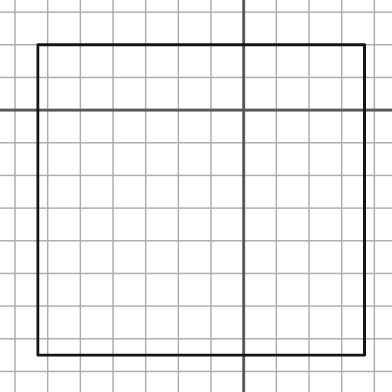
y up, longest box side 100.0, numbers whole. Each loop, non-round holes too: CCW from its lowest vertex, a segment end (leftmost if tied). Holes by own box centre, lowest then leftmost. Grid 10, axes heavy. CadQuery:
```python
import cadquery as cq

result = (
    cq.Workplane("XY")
    .moveTo(-63.0, -75.0)
    .lineTo(37.0, -75.0)
    .lineTo(37.0, 20.0)
    .lineTo(-63.0, 20.0)
    .close()
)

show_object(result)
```